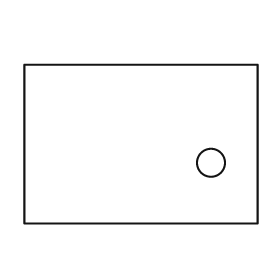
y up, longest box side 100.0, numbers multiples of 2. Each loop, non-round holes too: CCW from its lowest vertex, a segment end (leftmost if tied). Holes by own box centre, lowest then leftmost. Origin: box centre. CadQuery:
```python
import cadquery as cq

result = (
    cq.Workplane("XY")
    .moveTo(-50.0, -34.0)
    .lineTo(50.0, -34.0)
    .lineTo(50.0, 34.0)
    .lineTo(-50.0, 34.0)
    .close()
    .moveTo(30.0, -8.0)
    .circle(6.0)
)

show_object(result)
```